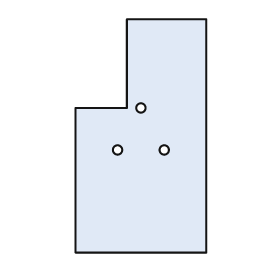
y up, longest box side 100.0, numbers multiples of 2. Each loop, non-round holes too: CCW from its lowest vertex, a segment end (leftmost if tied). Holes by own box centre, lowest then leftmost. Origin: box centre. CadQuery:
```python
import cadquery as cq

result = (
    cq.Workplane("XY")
    .moveTo(-28.0, -50.0)
    .lineTo(28.0, -50.0)
    .lineTo(28.0, 50.0)
    .lineTo(-6.0, 50.0)
    .lineTo(-6.0, 12.0)
    .lineTo(-28.0, 12.0)
    .close()
    .moveTo(-10.0, -6.0)
    .circle(2.0)
    .moveTo(10.0, -6.0)
    .circle(2.0)
    .moveTo(0.0, 12.0)
    .circle(2.0)
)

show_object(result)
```